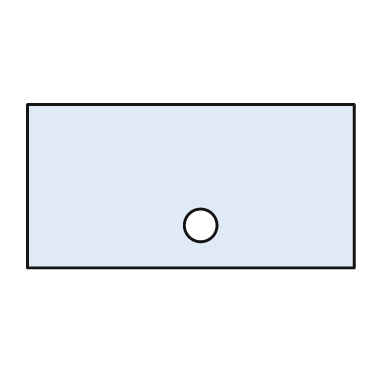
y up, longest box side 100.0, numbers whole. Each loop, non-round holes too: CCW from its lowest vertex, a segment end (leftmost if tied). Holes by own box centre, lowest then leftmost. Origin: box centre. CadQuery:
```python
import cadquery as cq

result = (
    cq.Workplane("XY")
    .moveTo(-50.0, -25.0)
    .lineTo(50.0, -25.0)
    .lineTo(50.0, 25.0)
    .lineTo(-50.0, 25.0)
    .close()
    .moveTo(3.0, -12.0)
    .circle(5.0)
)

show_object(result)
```